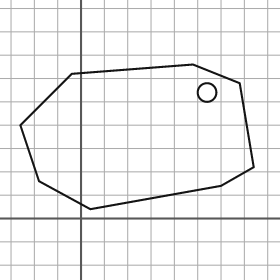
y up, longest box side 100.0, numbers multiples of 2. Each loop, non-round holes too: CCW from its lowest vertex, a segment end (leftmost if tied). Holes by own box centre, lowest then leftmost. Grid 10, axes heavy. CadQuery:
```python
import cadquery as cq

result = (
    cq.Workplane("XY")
    .moveTo(4.0, 4.0)
    .lineTo(60.0, 14.0)
    .lineTo(74.0, 22.0)
    .lineTo(68.0, 58.0)
    .lineTo(48.0, 66.0)
    .lineTo(-4.0, 62.0)
    .lineTo(-26.0, 40.0)
    .lineTo(-18.0, 16.0)
    .close()
    .moveTo(54.0, 54.0)
    .circle(4.0)
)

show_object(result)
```